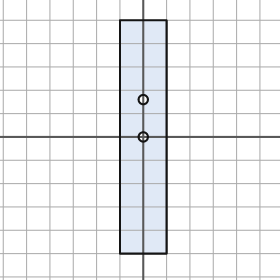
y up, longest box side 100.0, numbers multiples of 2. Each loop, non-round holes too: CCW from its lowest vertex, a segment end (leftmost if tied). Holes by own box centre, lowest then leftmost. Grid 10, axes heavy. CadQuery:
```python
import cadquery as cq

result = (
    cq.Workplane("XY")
    .moveTo(-10.0, -50.0)
    .lineTo(10.0, -50.0)
    .lineTo(10.0, 50.0)
    .lineTo(-10.0, 50.0)
    .close()
    .moveTo(0.0, 0.0)
    .circle(2.0)
    .moveTo(0.0, 16.0)
    .circle(2.0)
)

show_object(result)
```